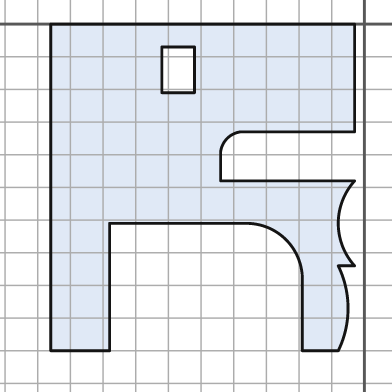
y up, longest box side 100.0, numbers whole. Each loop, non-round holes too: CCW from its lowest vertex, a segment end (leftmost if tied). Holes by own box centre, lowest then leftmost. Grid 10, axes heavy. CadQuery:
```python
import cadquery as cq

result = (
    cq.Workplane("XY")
    .moveTo(-96.0, -100.0)
    .lineTo(-78.0, -100.0)
    .lineTo(-78.0, -61.0)
    .lineTo(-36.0, -61.0)
    .threePointArc((-24.0, -66.0), (-19.0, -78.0))
    .lineTo(-19.0, -100.0)
    .lineTo(-8.0, -100.0)
    .threePointArc((-5.0, -87.0), (-8.0, -74.0))
    .lineTo(-3.0, -74.0)
    .threePointArc((-8.0, -61.0), (-3.0, -48.0))
    .lineTo(-44.0, -48.0)
    .lineTo(-44.0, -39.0)
    .threePointArc((-42.0, -35.0), (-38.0, -33.0))
    .lineTo(-3.0, -33.0)
    .lineTo(-3.0, 0.0)
    .lineTo(-96.0, 0.0)
    .close()
    .moveTo(-62.0, -21.0)
    .lineTo(-52.0, -21.0)
    .lineTo(-52.0, -7.0)
    .lineTo(-62.0, -7.0)
    .close()
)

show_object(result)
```